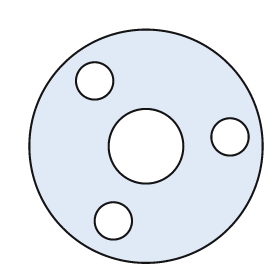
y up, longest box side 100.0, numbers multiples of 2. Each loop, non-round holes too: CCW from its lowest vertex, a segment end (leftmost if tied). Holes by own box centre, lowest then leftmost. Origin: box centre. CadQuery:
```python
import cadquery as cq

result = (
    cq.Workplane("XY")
    .moveTo(0.0, 0.0)
    .circle(50.0)
    .moveTo(-14.0, -32.0)
    .circle(8.0)
    .moveTo(0.0, 0.0)
    .circle(16.0)
    .moveTo(36.0, 4.0)
    .circle(8.0)
    .moveTo(-22.0, 28.0)
    .circle(8.0)
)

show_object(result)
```